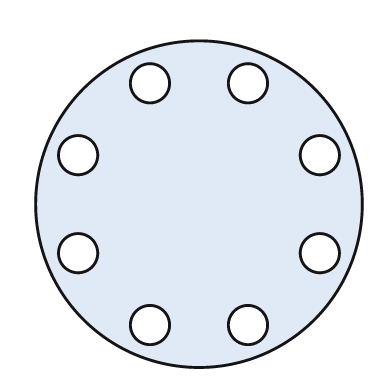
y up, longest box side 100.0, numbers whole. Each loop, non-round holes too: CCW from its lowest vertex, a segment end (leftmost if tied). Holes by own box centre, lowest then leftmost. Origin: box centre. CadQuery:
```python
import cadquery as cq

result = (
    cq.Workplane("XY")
    .moveTo(0.0, 0.0)
    .circle(50.0)
    .moveTo(-15.0, -37.0)
    .circle(6.0)
    .moveTo(15.0, -37.0)
    .circle(6.0)
    .moveTo(-37.0, -15.0)
    .circle(6.0)
    .moveTo(37.0, -15.0)
    .circle(6.0)
    .moveTo(-37.0, 15.0)
    .circle(6.0)
    .moveTo(37.0, 15.0)
    .circle(6.0)
    .moveTo(-15.0, 37.0)
    .circle(6.0)
    .moveTo(15.0, 37.0)
    .circle(6.0)
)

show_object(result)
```